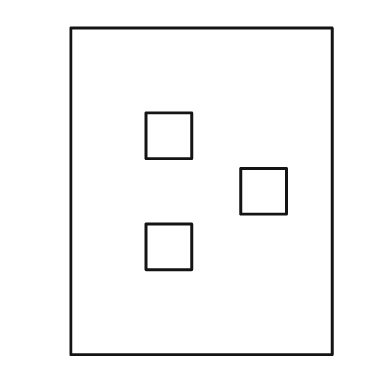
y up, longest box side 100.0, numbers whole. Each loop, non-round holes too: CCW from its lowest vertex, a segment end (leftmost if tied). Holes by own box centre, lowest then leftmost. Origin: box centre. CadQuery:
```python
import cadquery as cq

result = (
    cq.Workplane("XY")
    .moveTo(-40.0, -50.0)
    .lineTo(40.0, -50.0)
    .lineTo(40.0, 50.0)
    .lineTo(-40.0, 50.0)
    .close()
    .moveTo(-17.0, -24.0)
    .lineTo(-3.0, -24.0)
    .lineTo(-3.0, -10.0)
    .lineTo(-17.0, -10.0)
    .close()
    .moveTo(12.0, -7.0)
    .lineTo(26.0, -7.0)
    .lineTo(26.0, 7.0)
    .lineTo(12.0, 7.0)
    .close()
    .moveTo(-17.0, 10.0)
    .lineTo(-3.0, 10.0)
    .lineTo(-3.0, 24.0)
    .lineTo(-17.0, 24.0)
    .close()
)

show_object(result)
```